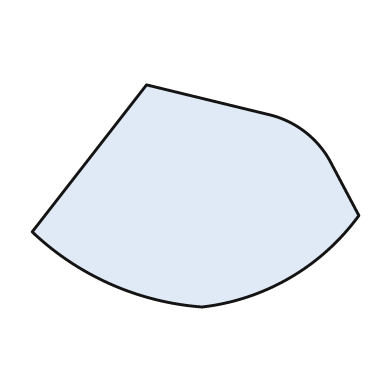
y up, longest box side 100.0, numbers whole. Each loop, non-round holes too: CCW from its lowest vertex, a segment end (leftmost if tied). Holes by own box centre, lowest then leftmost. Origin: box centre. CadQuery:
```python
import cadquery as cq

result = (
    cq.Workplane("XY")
    .moveTo(2.0, -34.0)
    .threePointArc((29.0, -25.0), (50.0, -6.0))
    .lineTo(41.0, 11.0)
    .threePointArc((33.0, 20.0), (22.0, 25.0))
    .lineTo(-15.0, 34.0)
    .lineTo(-50.0, -11.0)
    .threePointArc((-26.0, -27.0), (2.0, -34.0))
    .close()
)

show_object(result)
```